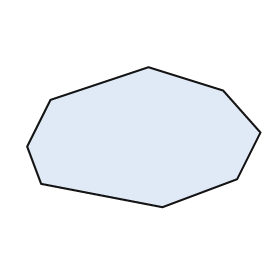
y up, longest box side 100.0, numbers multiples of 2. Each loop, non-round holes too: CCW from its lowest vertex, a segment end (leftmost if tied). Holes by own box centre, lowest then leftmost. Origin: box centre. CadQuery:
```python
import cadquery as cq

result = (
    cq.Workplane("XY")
    .moveTo(8.0, -30.0)
    .lineTo(40.0, -18.0)
    .lineTo(50.0, 2.0)
    .lineTo(34.0, 20.0)
    .lineTo(2.0, 30.0)
    .lineTo(-40.0, 16.0)
    .lineTo(-50.0, -4.0)
    .lineTo(-44.0, -20.0)
    .close()
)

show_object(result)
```